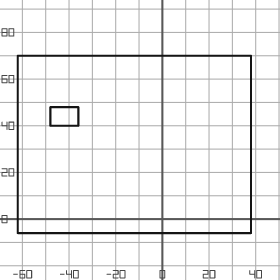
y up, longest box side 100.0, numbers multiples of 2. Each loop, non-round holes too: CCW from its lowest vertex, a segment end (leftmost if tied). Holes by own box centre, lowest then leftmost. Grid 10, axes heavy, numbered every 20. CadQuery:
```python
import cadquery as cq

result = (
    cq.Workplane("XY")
    .moveTo(-62.0, -6.0)
    .lineTo(38.0, -6.0)
    .lineTo(38.0, 70.0)
    .lineTo(-62.0, 70.0)
    .close()
    .moveTo(-48.0, 40.0)
    .lineTo(-36.0, 40.0)
    .lineTo(-36.0, 48.0)
    .lineTo(-48.0, 48.0)
    .close()
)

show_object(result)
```